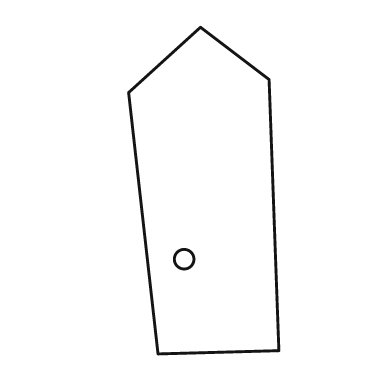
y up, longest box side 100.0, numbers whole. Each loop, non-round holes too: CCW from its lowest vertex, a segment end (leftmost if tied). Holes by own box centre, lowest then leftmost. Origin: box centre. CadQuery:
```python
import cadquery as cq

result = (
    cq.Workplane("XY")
    .moveTo(-14.0, -50.0)
    .lineTo(23.0, -49.0)
    .lineTo(20.0, 34.0)
    .lineTo(-1.0, 50.0)
    .lineTo(-23.0, 30.0)
    .close()
    .moveTo(-6.0, -21.0)
    .circle(3.0)
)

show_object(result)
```